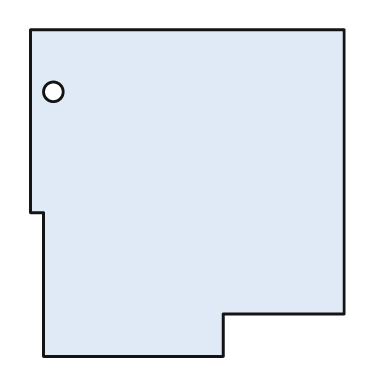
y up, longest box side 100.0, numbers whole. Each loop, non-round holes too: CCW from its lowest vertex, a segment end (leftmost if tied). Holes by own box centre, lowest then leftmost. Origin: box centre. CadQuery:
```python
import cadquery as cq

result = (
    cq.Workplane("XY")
    .moveTo(-44.0, -50.0)
    .lineTo(11.0, -50.0)
    .lineTo(11.0, -37.0)
    .lineTo(48.0, -37.0)
    .lineTo(48.0, 50.0)
    .lineTo(-48.0, 50.0)
    .lineTo(-48.0, -6.0)
    .lineTo(-44.0, -6.0)
    .close()
    .moveTo(-41.0, 31.0)
    .circle(3.0)
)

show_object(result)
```